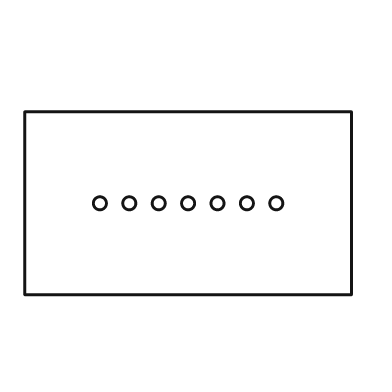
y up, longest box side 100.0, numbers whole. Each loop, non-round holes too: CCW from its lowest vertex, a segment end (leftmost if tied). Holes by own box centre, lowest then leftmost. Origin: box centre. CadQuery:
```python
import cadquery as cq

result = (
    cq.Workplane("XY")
    .moveTo(-50.0, -28.0)
    .lineTo(50.0, -28.0)
    .lineTo(50.0, 28.0)
    .lineTo(-50.0, 28.0)
    .close()
    .moveTo(-27.0, 0.0)
    .circle(2.0)
    .moveTo(-18.0, 0.0)
    .circle(2.0)
    .moveTo(-9.0, 0.0)
    .circle(2.0)
    .moveTo(0.0, 0.0)
    .circle(2.0)
    .moveTo(9.0, 0.0)
    .circle(2.0)
    .moveTo(18.0, 0.0)
    .circle(2.0)
    .moveTo(27.0, 0.0)
    .circle(2.0)
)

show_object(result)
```